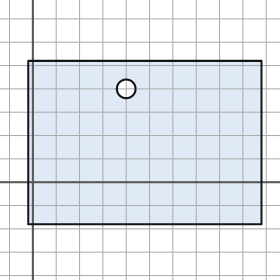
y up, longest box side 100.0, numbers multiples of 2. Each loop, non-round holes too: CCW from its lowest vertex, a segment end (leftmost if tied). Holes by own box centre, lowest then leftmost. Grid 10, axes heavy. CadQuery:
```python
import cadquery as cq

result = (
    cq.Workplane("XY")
    .moveTo(-2.0, -18.0)
    .lineTo(98.0, -18.0)
    .lineTo(98.0, 52.0)
    .lineTo(-2.0, 52.0)
    .close()
    .moveTo(40.0, 40.0)
    .circle(4.0)
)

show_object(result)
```